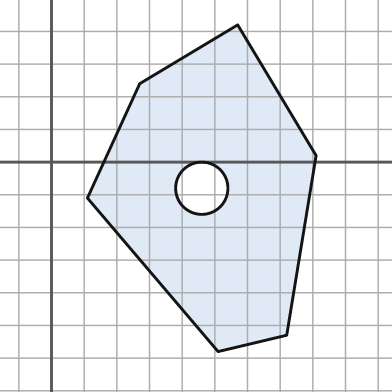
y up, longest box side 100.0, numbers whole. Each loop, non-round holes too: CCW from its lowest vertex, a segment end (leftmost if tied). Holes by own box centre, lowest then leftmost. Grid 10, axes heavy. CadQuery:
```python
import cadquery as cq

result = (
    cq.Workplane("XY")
    .moveTo(51.0, -58.0)
    .lineTo(72.0, -53.0)
    .lineTo(81.0, 2.0)
    .lineTo(57.0, 42.0)
    .lineTo(27.0, 24.0)
    .lineTo(11.0, -11.0)
    .close()
    .moveTo(46.0, -8.0)
    .circle(8.0)
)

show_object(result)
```